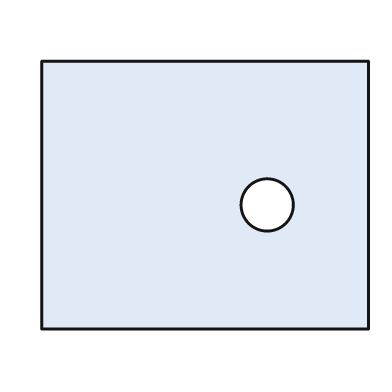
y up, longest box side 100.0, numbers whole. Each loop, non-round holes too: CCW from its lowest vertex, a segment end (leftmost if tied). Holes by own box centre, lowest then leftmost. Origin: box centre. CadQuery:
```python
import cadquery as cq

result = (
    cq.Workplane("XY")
    .moveTo(-50.0, -41.0)
    .lineTo(50.0, -41.0)
    .lineTo(50.0, 41.0)
    .lineTo(-50.0, 41.0)
    .close()
    .moveTo(19.0, -3.0)
    .circle(8.0)
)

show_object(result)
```